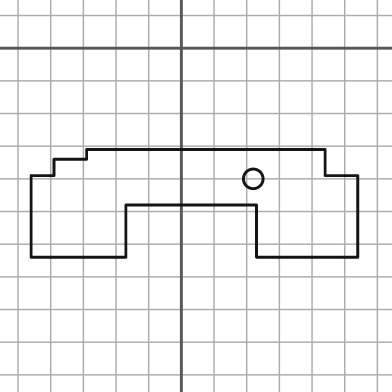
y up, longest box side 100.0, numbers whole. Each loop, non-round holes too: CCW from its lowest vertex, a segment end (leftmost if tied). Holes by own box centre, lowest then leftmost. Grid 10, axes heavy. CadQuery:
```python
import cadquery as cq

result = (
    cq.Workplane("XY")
    .moveTo(-46.0, -64.0)
    .lineTo(-17.0, -64.0)
    .lineTo(-17.0, -48.0)
    .lineTo(23.0, -48.0)
    .lineTo(23.0, -64.0)
    .lineTo(54.0, -64.0)
    .lineTo(54.0, -39.0)
    .lineTo(44.0, -39.0)
    .lineTo(44.0, -31.0)
    .lineTo(-29.0, -31.0)
    .lineTo(-29.0, -34.0)
    .lineTo(-39.0, -34.0)
    .lineTo(-39.0, -39.0)
    .lineTo(-46.0, -39.0)
    .close()
    .moveTo(22.0, -40.0)
    .circle(3.0)
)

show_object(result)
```